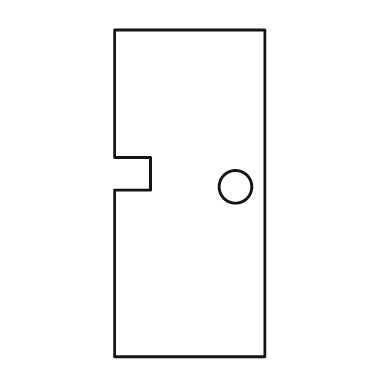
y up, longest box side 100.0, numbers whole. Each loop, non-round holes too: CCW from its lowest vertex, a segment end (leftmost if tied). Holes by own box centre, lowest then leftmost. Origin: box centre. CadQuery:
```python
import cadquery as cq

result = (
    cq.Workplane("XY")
    .moveTo(-23.0, -50.0)
    .lineTo(23.0, -50.0)
    .lineTo(23.0, 50.0)
    .lineTo(-23.0, 50.0)
    .lineTo(-23.0, 11.0)
    .lineTo(-12.0, 11.0)
    .lineTo(-12.0, 1.0)
    .lineTo(-23.0, 1.0)
    .close()
    .moveTo(14.0, 2.0)
    .circle(5.0)
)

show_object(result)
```